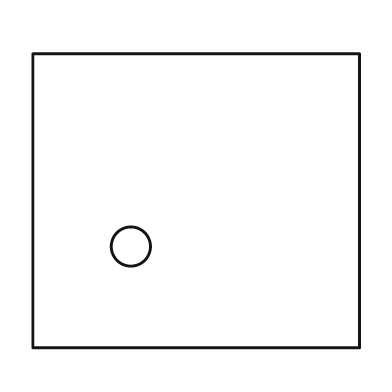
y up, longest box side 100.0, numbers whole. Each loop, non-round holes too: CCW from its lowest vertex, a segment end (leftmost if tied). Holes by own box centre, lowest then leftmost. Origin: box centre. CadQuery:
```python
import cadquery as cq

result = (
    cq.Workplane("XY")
    .moveTo(-50.0, -45.0)
    .lineTo(50.0, -45.0)
    .lineTo(50.0, 45.0)
    .lineTo(-50.0, 45.0)
    .close()
    .moveTo(-20.0, -14.0)
    .circle(6.0)
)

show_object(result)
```